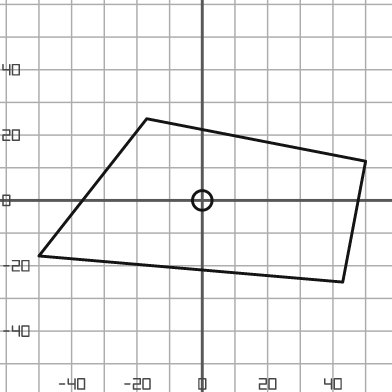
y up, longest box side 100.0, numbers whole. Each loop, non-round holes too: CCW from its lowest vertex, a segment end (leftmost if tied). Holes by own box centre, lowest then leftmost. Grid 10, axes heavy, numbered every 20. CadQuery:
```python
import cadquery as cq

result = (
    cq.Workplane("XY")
    .moveTo(43.0, -25.0)
    .lineTo(50.0, 12.0)
    .lineTo(-17.0, 25.0)
    .lineTo(-50.0, -17.0)
    .close()
    .moveTo(0.0, 0.0)
    .circle(3.0)
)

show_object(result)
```